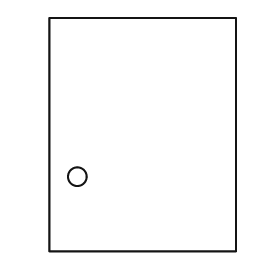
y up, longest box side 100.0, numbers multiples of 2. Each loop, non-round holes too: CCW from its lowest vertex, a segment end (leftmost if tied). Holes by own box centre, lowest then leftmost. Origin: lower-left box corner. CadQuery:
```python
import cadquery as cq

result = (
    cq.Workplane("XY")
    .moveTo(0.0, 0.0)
    .lineTo(80.0, 0.0)
    .lineTo(80.0, 100.0)
    .lineTo(0.0, 100.0)
    .close()
    .moveTo(12.0, 32.0)
    .circle(4.0)
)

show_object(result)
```